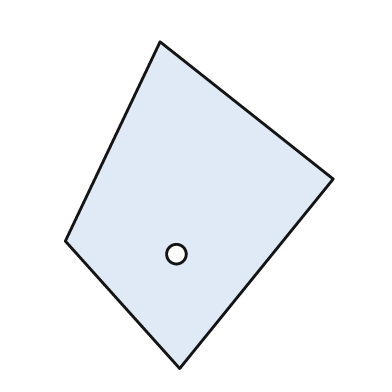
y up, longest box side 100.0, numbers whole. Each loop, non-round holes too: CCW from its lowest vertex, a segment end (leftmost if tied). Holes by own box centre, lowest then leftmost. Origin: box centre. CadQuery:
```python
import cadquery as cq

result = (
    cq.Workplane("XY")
    .moveTo(-6.0, -50.0)
    .lineTo(41.0, 8.0)
    .lineTo(-12.0, 50.0)
    .lineTo(-41.0, -11.0)
    .close()
    .moveTo(-7.0, -15.0)
    .circle(3.0)
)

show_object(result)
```